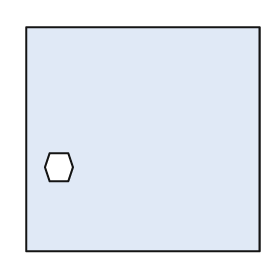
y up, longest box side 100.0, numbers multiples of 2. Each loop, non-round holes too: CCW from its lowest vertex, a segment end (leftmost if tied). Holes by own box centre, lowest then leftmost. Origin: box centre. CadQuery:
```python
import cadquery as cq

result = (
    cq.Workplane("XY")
    .moveTo(-50.0, -48.0)
    .lineTo(50.0, -48.0)
    .lineTo(50.0, 48.0)
    .lineTo(-50.0, 48.0)
    .close()
    .moveTo(-40.0, -18.0)
    .lineTo(-32.0, -18.0)
    .lineTo(-30.0, -12.0)
    .lineTo(-32.0, -6.0)
    .lineTo(-40.0, -6.0)
    .lineTo(-42.0, -12.0)
    .close()
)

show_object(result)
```